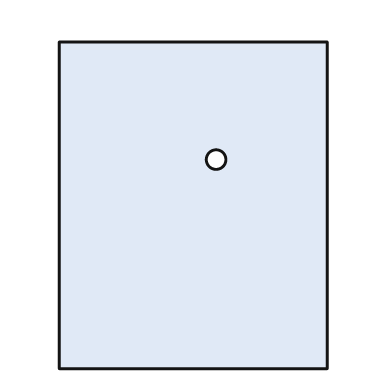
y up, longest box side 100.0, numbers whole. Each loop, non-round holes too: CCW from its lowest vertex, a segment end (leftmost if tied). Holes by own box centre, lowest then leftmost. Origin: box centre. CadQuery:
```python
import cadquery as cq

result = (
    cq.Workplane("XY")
    .moveTo(-41.0, -50.0)
    .lineTo(41.0, -50.0)
    .lineTo(41.0, 50.0)
    .lineTo(-41.0, 50.0)
    .close()
    .moveTo(7.0, 14.0)
    .circle(3.0)
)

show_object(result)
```